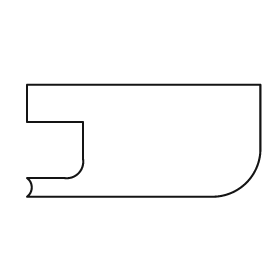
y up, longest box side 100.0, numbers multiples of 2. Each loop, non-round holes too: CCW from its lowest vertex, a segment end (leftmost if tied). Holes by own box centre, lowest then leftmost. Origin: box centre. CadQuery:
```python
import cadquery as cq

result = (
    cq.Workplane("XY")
    .moveTo(-50.0, -24.0)
    .lineTo(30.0, -24.0)
    .threePointArc((44.0, -18.0), (50.0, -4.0))
    .lineTo(50.0, 24.0)
    .lineTo(-50.0, 24.0)
    .lineTo(-50.0, 8.0)
    .lineTo(-26.0, 8.0)
    .lineTo(-26.0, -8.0)
    .threePointArc((-28.0, -14.0), (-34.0, -16.0))
    .lineTo(-50.0, -16.0)
    .threePointArc((-48.0, -20.0), (-50.0, -24.0))
    .close()
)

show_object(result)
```